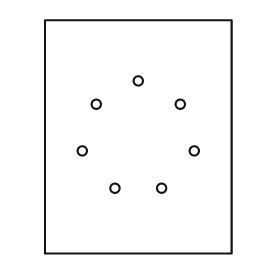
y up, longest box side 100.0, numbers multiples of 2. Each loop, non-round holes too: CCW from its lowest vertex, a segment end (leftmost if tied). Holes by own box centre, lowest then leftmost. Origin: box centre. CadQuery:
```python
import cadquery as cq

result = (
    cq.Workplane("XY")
    .moveTo(-40.0, -50.0)
    .lineTo(40.0, -50.0)
    .lineTo(40.0, 50.0)
    .lineTo(-40.0, 50.0)
    .close()
    .moveTo(-10.0, -22.0)
    .circle(2.0)
    .moveTo(10.0, -22.0)
    .circle(2.0)
    .moveTo(-24.0, -6.0)
    .circle(2.0)
    .moveTo(24.0, -6.0)
    .circle(2.0)
    .moveTo(-18.0, 14.0)
    .circle(2.0)
    .moveTo(18.0, 14.0)
    .circle(2.0)
    .moveTo(0.0, 24.0)
    .circle(2.0)
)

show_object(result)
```